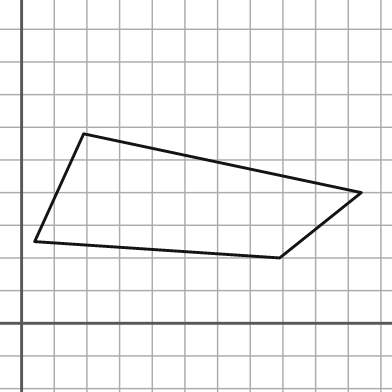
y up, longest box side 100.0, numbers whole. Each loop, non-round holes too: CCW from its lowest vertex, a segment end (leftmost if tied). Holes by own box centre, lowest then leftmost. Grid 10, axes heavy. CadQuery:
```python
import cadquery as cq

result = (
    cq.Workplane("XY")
    .moveTo(79.0, 20.0)
    .lineTo(104.0, 40.0)
    .lineTo(19.0, 58.0)
    .lineTo(4.0, 25.0)
    .close()
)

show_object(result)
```